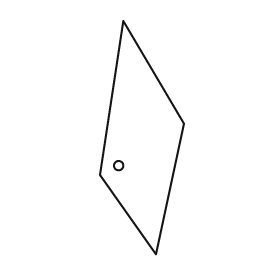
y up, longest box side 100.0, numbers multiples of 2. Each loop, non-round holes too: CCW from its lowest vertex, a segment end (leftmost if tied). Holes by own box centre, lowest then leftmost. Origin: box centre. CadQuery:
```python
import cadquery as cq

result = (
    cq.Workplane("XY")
    .moveTo(6.0, -50.0)
    .lineTo(18.0, 6.0)
    .lineTo(-8.0, 50.0)
    .lineTo(-18.0, -16.0)
    .close()
    .moveTo(-10.0, -12.0)
    .circle(2.0)
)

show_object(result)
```